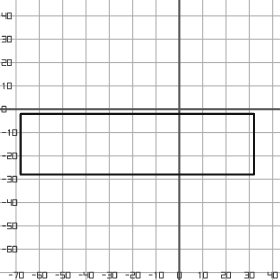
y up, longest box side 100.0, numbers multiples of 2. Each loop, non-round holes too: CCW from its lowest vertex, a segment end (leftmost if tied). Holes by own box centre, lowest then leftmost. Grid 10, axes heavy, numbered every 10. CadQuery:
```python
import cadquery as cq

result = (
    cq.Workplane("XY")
    .moveTo(-68.0, -28.0)
    .lineTo(32.0, -28.0)
    .lineTo(32.0, -2.0)
    .lineTo(-68.0, -2.0)
    .close()
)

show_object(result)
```